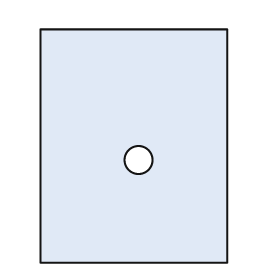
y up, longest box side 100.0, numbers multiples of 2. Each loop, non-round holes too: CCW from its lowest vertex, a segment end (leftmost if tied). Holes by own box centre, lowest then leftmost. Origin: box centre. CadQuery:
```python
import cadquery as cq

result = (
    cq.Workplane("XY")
    .moveTo(-40.0, -50.0)
    .lineTo(40.0, -50.0)
    .lineTo(40.0, 50.0)
    .lineTo(-40.0, 50.0)
    .close()
    .moveTo(2.0, -6.0)
    .circle(6.0)
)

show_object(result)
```